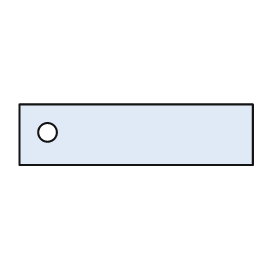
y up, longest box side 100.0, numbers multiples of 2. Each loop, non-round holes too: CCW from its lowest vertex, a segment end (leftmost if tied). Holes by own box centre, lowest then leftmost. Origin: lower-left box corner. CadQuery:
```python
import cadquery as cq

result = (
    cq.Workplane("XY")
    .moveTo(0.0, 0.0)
    .lineTo(100.0, 0.0)
    .lineTo(100.0, 26.0)
    .lineTo(0.0, 26.0)
    .close()
    .moveTo(12.0, 14.0)
    .circle(4.0)
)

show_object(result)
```